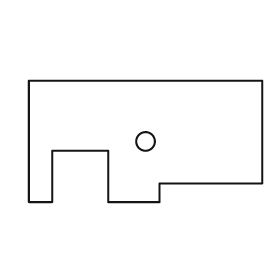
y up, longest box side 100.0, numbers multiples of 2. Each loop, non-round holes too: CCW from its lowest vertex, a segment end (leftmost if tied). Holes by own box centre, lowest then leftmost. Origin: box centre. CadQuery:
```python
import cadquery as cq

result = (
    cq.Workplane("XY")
    .moveTo(-50.0, -26.0)
    .lineTo(-40.0, -26.0)
    .lineTo(-40.0, -4.0)
    .lineTo(-16.0, -4.0)
    .lineTo(-16.0, -26.0)
    .lineTo(6.0, -26.0)
    .lineTo(6.0, -18.0)
    .lineTo(50.0, -18.0)
    .lineTo(50.0, 26.0)
    .lineTo(-50.0, 26.0)
    .close()
    .moveTo(0.0, 0.0)
    .circle(4.0)
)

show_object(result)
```